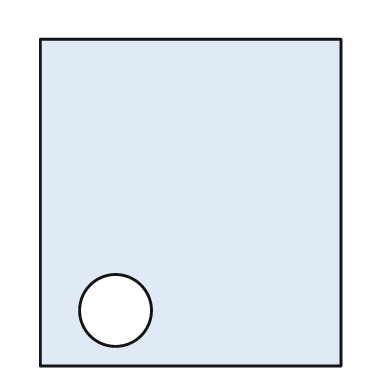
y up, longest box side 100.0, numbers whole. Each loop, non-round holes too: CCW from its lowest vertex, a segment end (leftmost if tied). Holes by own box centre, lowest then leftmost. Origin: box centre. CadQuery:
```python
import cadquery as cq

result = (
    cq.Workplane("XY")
    .moveTo(-46.0, -50.0)
    .lineTo(46.0, -50.0)
    .lineTo(46.0, 50.0)
    .lineTo(-46.0, 50.0)
    .close()
    .moveTo(-23.0, -33.0)
    .circle(11.0)
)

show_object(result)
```